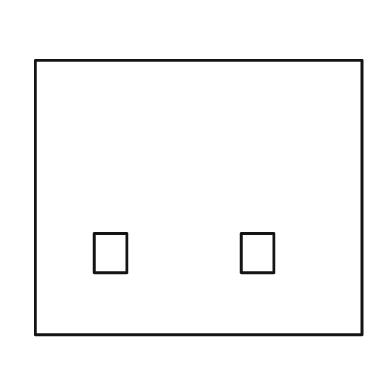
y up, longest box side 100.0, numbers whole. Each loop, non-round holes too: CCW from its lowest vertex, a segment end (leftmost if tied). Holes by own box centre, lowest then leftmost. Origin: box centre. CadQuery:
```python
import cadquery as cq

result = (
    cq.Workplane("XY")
    .moveTo(-50.0, -42.0)
    .lineTo(50.0, -42.0)
    .lineTo(50.0, 42.0)
    .lineTo(-50.0, 42.0)
    .close()
    .moveTo(-32.0, -23.0)
    .lineTo(-22.0, -23.0)
    .lineTo(-22.0, -11.0)
    .lineTo(-32.0, -11.0)
    .close()
    .moveTo(13.0, -23.0)
    .lineTo(23.0, -23.0)
    .lineTo(23.0, -11.0)
    .lineTo(13.0, -11.0)
    .close()
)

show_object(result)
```